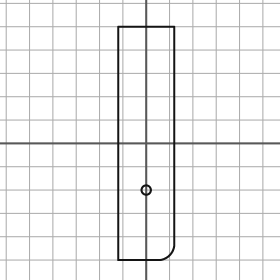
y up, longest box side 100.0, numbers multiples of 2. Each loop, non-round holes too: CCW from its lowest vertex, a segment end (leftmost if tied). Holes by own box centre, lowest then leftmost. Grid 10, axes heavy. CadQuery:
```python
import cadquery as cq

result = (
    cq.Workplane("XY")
    .moveTo(-12.0, -50.0)
    .lineTo(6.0, -50.0)
    .threePointArc((10.0, -48.0), (12.0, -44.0))
    .lineTo(12.0, 50.0)
    .lineTo(-12.0, 50.0)
    .close()
    .moveTo(0.0, -20.0)
    .circle(2.0)
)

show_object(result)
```